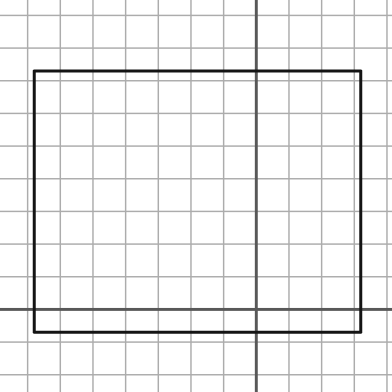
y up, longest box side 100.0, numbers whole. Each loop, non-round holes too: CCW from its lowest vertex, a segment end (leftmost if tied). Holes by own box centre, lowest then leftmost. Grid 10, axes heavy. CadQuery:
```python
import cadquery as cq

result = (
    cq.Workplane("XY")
    .moveTo(-68.0, -7.0)
    .lineTo(32.0, -7.0)
    .lineTo(32.0, 73.0)
    .lineTo(-68.0, 73.0)
    .close()
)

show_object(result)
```